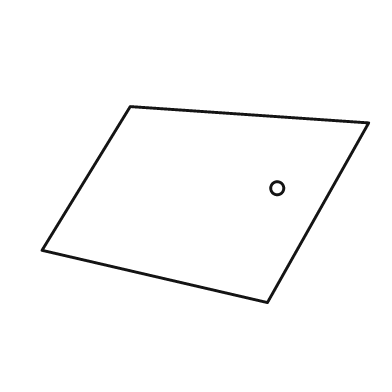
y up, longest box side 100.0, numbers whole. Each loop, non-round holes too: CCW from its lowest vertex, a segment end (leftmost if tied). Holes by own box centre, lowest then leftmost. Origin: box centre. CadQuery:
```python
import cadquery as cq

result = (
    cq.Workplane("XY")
    .moveTo(19.0, -30.0)
    .lineTo(50.0, 25.0)
    .lineTo(-23.0, 30.0)
    .lineTo(-50.0, -14.0)
    .close()
    .moveTo(22.0, 5.0)
    .circle(2.0)
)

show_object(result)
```